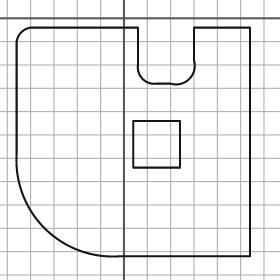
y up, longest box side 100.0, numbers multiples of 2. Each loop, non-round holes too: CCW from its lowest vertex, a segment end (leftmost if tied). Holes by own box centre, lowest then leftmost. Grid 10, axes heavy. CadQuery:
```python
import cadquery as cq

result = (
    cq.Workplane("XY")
    .moveTo(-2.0, -102.0)
    .lineTo(54.0, -102.0)
    .lineTo(54.0, -4.0)
    .lineTo(30.0, -4.0)
    .lineTo(30.0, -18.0)
    .threePointArc((28.0, -26.0), (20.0, -28.0))
    .lineTo(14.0, -28.0)
    .threePointArc((8.0, -26.0), (6.0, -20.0))
    .lineTo(6.0, -4.0)
    .lineTo(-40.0, -4.0)
    .threePointArc((-44.0, -6.0), (-46.0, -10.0))
    .lineTo(-46.0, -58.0)
    .threePointArc((-34.0, -90.0), (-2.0, -102.0))
    .close()
    .moveTo(4.0, -64.0)
    .lineTo(24.0, -64.0)
    .lineTo(24.0, -44.0)
    .lineTo(4.0, -44.0)
    .close()
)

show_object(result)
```